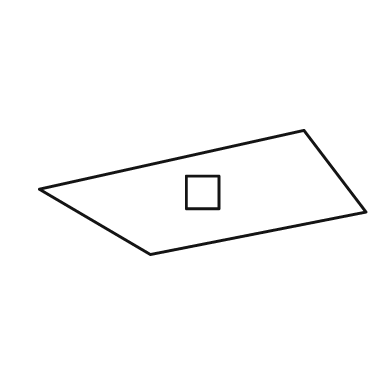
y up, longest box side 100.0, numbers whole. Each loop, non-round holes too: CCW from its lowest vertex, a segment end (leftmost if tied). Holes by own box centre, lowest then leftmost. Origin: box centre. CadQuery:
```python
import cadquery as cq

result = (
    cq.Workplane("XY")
    .moveTo(-16.0, -19.0)
    .lineTo(50.0, -6.0)
    .lineTo(31.0, 19.0)
    .lineTo(-50.0, 1.0)
    .close()
    .moveTo(-5.0, -5.0)
    .lineTo(5.0, -5.0)
    .lineTo(5.0, 5.0)
    .lineTo(-5.0, 5.0)
    .close()
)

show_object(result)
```